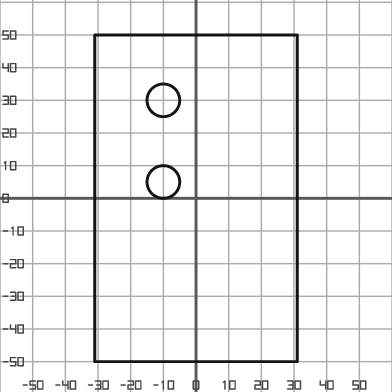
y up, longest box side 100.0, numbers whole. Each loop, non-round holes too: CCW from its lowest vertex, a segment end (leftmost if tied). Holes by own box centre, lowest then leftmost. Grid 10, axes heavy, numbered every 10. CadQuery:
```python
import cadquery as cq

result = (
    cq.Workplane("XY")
    .moveTo(-31.0, -50.0)
    .lineTo(31.0, -50.0)
    .lineTo(31.0, 50.0)
    .lineTo(-31.0, 50.0)
    .close()
    .moveTo(-10.0, 5.0)
    .circle(5.0)
    .moveTo(-10.0, 30.0)
    .circle(5.0)
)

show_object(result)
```